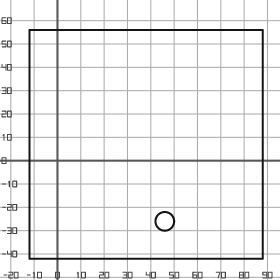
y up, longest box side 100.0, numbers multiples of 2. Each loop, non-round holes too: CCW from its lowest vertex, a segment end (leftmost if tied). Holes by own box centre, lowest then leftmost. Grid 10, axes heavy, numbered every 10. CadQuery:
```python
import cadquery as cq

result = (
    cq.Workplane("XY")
    .moveTo(-12.0, -42.0)
    .lineTo(88.0, -42.0)
    .lineTo(88.0, 56.0)
    .lineTo(-12.0, 56.0)
    .close()
    .moveTo(46.0, -26.0)
    .circle(4.0)
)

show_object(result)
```